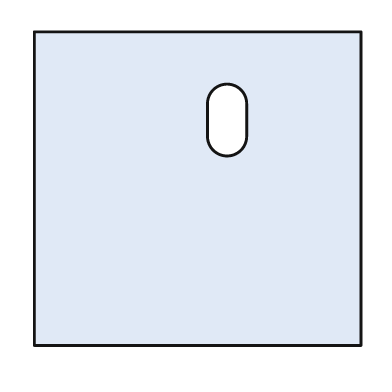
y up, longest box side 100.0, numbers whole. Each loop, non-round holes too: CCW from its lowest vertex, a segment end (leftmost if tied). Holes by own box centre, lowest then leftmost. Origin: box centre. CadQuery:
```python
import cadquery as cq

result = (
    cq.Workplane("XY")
    .moveTo(-50.0, -48.0)
    .lineTo(50.0, -48.0)
    .lineTo(50.0, 48.0)
    .lineTo(-50.0, 48.0)
    .close()
    .moveTo(3.0, 16.0)
    .threePointArc((9.0, 10.0), (15.0, 16.0))
    .lineTo(15.0, 26.0)
    .threePointArc((9.0, 32.0), (3.0, 26.0))
    .close()
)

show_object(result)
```